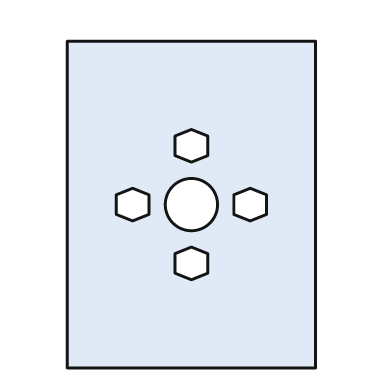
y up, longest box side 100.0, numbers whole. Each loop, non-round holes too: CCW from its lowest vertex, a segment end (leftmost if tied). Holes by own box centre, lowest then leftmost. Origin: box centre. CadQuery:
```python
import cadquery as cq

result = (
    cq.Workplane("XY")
    .moveTo(-38.0, -50.0)
    .lineTo(38.0, -50.0)
    .lineTo(38.0, 50.0)
    .lineTo(-38.0, 50.0)
    .close()
    .moveTo(0.0, -23.0)
    .lineTo(5.0, -21.0)
    .lineTo(5.0, -15.0)
    .lineTo(0.0, -13.0)
    .lineTo(-5.0, -15.0)
    .lineTo(-5.0, -21.0)
    .close()
    .moveTo(-18.0, -5.0)
    .lineTo(-13.0, -3.0)
    .lineTo(-13.0, 3.0)
    .lineTo(-18.0, 5.0)
    .lineTo(-23.0, 3.0)
    .lineTo(-23.0, -3.0)
    .close()
    .moveTo(0.0, 0.0)
    .circle(8.0)
    .moveTo(18.0, -5.0)
    .lineTo(23.0, -3.0)
    .lineTo(23.0, 3.0)
    .lineTo(18.0, 5.0)
    .lineTo(13.0, 3.0)
    .lineTo(13.0, -3.0)
    .close()
    .moveTo(0.0, 13.0)
    .lineTo(5.0, 15.0)
    .lineTo(5.0, 21.0)
    .lineTo(0.0, 23.0)
    .lineTo(-5.0, 21.0)
    .lineTo(-5.0, 15.0)
    .close()
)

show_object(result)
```